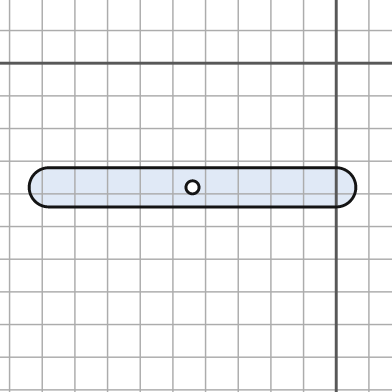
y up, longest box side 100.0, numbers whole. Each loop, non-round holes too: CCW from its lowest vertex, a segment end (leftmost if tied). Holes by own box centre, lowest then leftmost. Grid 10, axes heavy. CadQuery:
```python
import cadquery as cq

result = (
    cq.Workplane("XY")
    .moveTo(-88.0, -44.0)
    .lineTo(0.0, -44.0)
    .threePointArc((6.0, -38.0), (0.0, -32.0))
    .lineTo(-88.0, -32.0)
    .threePointArc((-94.0, -38.0), (-88.0, -44.0))
    .close()
    .moveTo(-44.0, -38.0)
    .circle(2.0)
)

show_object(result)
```